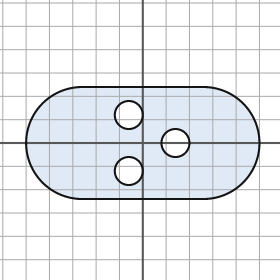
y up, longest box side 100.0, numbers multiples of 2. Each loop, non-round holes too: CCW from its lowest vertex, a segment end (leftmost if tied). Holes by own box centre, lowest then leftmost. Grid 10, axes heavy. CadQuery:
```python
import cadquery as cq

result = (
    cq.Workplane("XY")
    .moveTo(-26.0, -24.0)
    .lineTo(26.0, -24.0)
    .threePointArc((50.0, 0.0), (26.0, 24.0))
    .lineTo(-26.0, 24.0)
    .threePointArc((-50.0, 0.0), (-26.0, -24.0))
    .close()
    .moveTo(-6.0, -12.0)
    .circle(6.0)
    .moveTo(14.0, 0.0)
    .circle(6.0)
    .moveTo(-6.0, 12.0)
    .circle(6.0)
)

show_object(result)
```